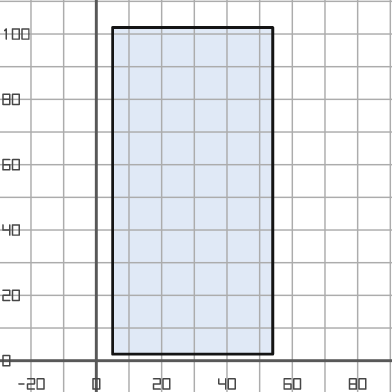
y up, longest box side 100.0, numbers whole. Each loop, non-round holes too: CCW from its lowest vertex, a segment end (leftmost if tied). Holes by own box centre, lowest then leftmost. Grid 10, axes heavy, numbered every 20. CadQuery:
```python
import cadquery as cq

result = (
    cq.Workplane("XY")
    .moveTo(5.0, 2.0)
    .lineTo(54.0, 2.0)
    .lineTo(54.0, 102.0)
    .lineTo(5.0, 102.0)
    .close()
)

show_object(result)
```